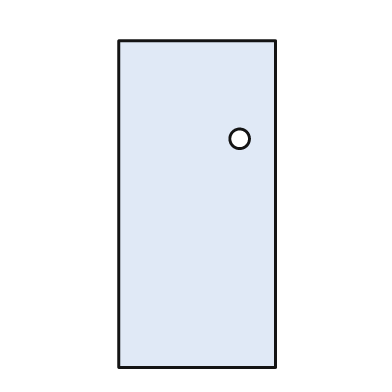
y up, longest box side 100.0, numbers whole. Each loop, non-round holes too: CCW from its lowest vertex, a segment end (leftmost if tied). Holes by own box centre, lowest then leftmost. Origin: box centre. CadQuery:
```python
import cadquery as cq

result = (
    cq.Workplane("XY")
    .moveTo(-24.0, -50.0)
    .lineTo(24.0, -50.0)
    .lineTo(24.0, 50.0)
    .lineTo(-24.0, 50.0)
    .close()
    .moveTo(13.0, 20.0)
    .circle(3.0)
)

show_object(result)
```